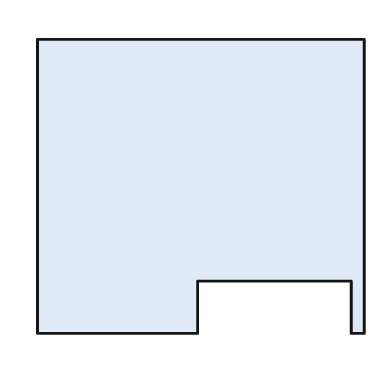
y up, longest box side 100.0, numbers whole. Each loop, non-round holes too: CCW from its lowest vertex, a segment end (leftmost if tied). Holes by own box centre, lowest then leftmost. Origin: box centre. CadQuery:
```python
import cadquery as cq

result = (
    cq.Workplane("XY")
    .moveTo(-50.0, -45.0)
    .lineTo(-1.0, -45.0)
    .lineTo(-1.0, -29.0)
    .lineTo(46.0, -29.0)
    .lineTo(46.0, -45.0)
    .lineTo(50.0, -45.0)
    .lineTo(50.0, 45.0)
    .lineTo(-50.0, 45.0)
    .close()
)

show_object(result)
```